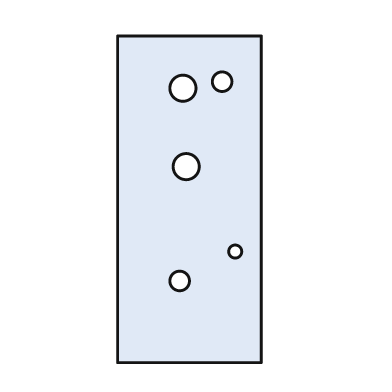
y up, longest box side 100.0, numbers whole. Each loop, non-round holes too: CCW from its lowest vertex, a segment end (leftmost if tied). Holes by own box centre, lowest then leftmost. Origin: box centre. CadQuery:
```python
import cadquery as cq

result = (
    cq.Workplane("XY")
    .moveTo(-22.0, -50.0)
    .lineTo(22.0, -50.0)
    .lineTo(22.0, 50.0)
    .lineTo(-22.0, 50.0)
    .close()
    .moveTo(-3.0, -25.0)
    .circle(3.0)
    .moveTo(14.0, -16.0)
    .circle(2.0)
    .moveTo(-1.0, 10.0)
    .circle(4.0)
    .moveTo(-2.0, 34.0)
    .circle(4.0)
    .moveTo(10.0, 36.0)
    .circle(3.0)
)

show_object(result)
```